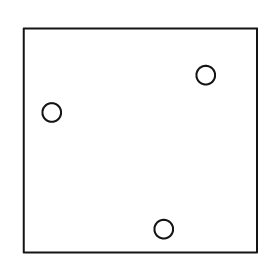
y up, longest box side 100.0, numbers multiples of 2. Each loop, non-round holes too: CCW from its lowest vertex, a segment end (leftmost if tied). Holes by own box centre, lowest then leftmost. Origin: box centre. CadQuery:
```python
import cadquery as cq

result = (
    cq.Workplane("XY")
    .moveTo(-50.0, -48.0)
    .lineTo(50.0, -48.0)
    .lineTo(50.0, 48.0)
    .lineTo(-50.0, 48.0)
    .close()
    .moveTo(10.0, -38.0)
    .circle(4.0)
    .moveTo(-38.0, 12.0)
    .circle(4.0)
    .moveTo(28.0, 28.0)
    .circle(4.0)
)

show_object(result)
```